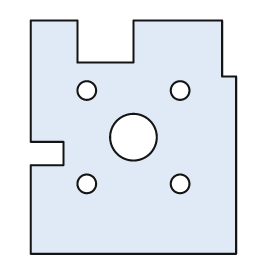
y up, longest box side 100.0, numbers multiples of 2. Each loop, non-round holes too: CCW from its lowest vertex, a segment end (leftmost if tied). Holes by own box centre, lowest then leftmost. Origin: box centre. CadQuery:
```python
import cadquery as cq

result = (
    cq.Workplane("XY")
    .moveTo(-44.0, -50.0)
    .lineTo(44.0, -50.0)
    .lineTo(44.0, 26.0)
    .lineTo(38.0, 26.0)
    .lineTo(38.0, 50.0)
    .lineTo(0.0, 50.0)
    .lineTo(0.0, 32.0)
    .lineTo(-24.0, 32.0)
    .lineTo(-24.0, 50.0)
    .lineTo(-44.0, 50.0)
    .lineTo(-44.0, -2.0)
    .lineTo(-30.0, -2.0)
    .lineTo(-30.0, -12.0)
    .lineTo(-44.0, -12.0)
    .close()
    .moveTo(-20.0, -20.0)
    .circle(4.0)
    .moveTo(20.0, -20.0)
    .circle(4.0)
    .moveTo(0.0, 0.0)
    .circle(10.0)
    .moveTo(-20.0, 20.0)
    .circle(4.0)
    .moveTo(20.0, 20.0)
    .circle(4.0)
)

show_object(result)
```